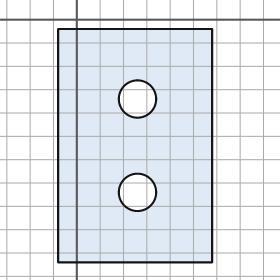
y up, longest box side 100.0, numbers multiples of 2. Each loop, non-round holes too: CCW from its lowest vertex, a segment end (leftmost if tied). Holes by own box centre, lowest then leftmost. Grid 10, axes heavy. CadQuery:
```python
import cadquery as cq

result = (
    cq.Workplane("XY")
    .moveTo(-8.0, -104.0)
    .lineTo(58.0, -104.0)
    .lineTo(58.0, -4.0)
    .lineTo(-8.0, -4.0)
    .close()
    .moveTo(26.0, -74.0)
    .circle(8.0)
    .moveTo(26.0, -34.0)
    .circle(8.0)
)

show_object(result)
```